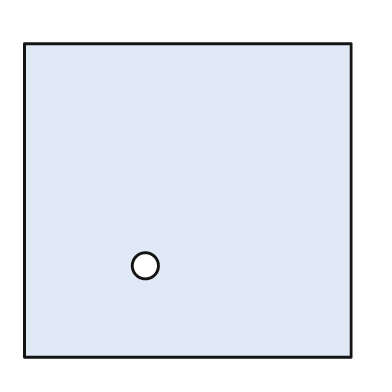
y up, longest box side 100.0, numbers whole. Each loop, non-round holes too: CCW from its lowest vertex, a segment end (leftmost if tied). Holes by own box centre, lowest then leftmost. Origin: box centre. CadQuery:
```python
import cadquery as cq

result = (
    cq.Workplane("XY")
    .moveTo(-50.0, -48.0)
    .lineTo(50.0, -48.0)
    .lineTo(50.0, 48.0)
    .lineTo(-50.0, 48.0)
    .close()
    .moveTo(-13.0, -20.0)
    .circle(4.0)
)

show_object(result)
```